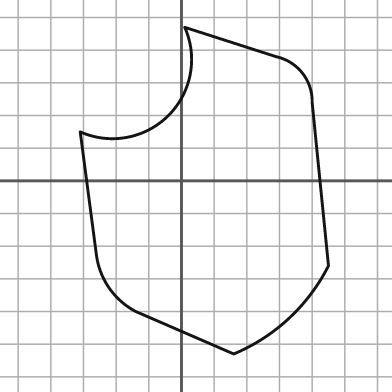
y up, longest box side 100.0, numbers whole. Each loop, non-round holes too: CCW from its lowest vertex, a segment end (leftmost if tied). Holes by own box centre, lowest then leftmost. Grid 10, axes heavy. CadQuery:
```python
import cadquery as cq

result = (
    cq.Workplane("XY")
    .moveTo(16.0, -53.0)
    .threePointArc((33.0, -42.0), (45.0, -26.0))
    .lineTo(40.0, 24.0)
    .threePointArc((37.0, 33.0), (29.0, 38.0))
    .lineTo(1.0, 47.0)
    .threePointArc((-4.0, 20.0), (-31.0, 15.0))
    .lineTo(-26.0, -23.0)
    .threePointArc((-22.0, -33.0), (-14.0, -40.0))
    .close()
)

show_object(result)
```